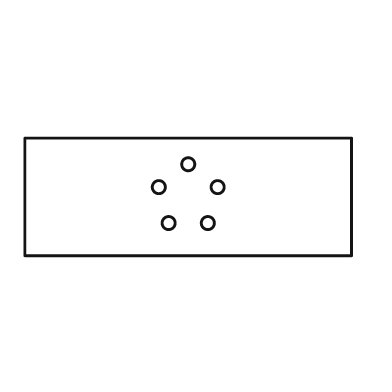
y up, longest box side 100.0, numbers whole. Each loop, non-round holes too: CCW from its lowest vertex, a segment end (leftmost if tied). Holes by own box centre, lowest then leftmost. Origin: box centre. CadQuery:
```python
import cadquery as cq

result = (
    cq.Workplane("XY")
    .moveTo(-50.0, -18.0)
    .lineTo(50.0, -18.0)
    .lineTo(50.0, 18.0)
    .lineTo(-50.0, 18.0)
    .close()
    .moveTo(-6.0, -8.0)
    .circle(2.0)
    .moveTo(6.0, -8.0)
    .circle(2.0)
    .moveTo(-9.0, 3.0)
    .circle(2.0)
    .moveTo(9.0, 3.0)
    .circle(2.0)
    .moveTo(0.0, 10.0)
    .circle(2.0)
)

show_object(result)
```